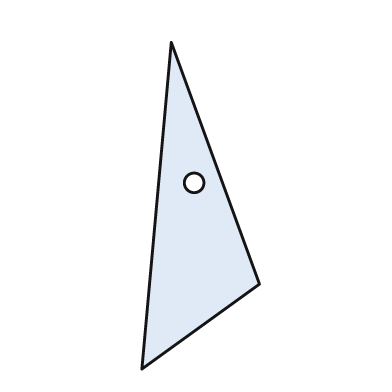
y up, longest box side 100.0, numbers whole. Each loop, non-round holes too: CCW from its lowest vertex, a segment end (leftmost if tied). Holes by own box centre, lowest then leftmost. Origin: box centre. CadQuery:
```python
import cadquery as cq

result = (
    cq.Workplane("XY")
    .moveTo(-18.0, -50.0)
    .lineTo(18.0, -24.0)
    .lineTo(-9.0, 50.0)
    .close()
    .moveTo(-2.0, 7.0)
    .circle(3.0)
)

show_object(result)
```